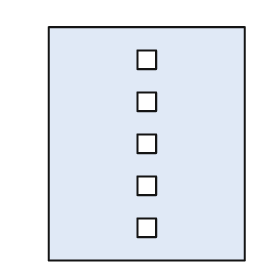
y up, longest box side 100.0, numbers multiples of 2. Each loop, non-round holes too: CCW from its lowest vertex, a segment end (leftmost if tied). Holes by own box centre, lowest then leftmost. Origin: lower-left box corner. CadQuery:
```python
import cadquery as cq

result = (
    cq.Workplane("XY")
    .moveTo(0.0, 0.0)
    .lineTo(84.0, 0.0)
    .lineTo(84.0, 100.0)
    .lineTo(0.0, 100.0)
    .close()
    .moveTo(38.0, 10.0)
    .lineTo(46.0, 10.0)
    .lineTo(46.0, 18.0)
    .lineTo(38.0, 18.0)
    .close()
    .moveTo(38.0, 28.0)
    .lineTo(46.0, 28.0)
    .lineTo(46.0, 36.0)
    .lineTo(38.0, 36.0)
    .close()
    .moveTo(38.0, 46.0)
    .lineTo(46.0, 46.0)
    .lineTo(46.0, 54.0)
    .lineTo(38.0, 54.0)
    .close()
    .moveTo(38.0, 64.0)
    .lineTo(46.0, 64.0)
    .lineTo(46.0, 72.0)
    .lineTo(38.0, 72.0)
    .close()
    .moveTo(38.0, 82.0)
    .lineTo(46.0, 82.0)
    .lineTo(46.0, 90.0)
    .lineTo(38.0, 90.0)
    .close()
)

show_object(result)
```